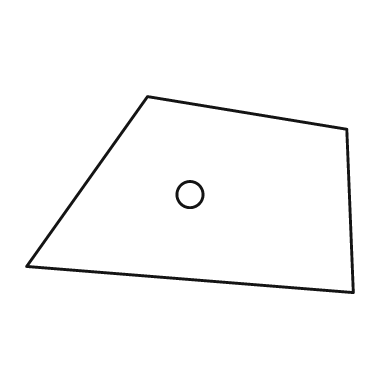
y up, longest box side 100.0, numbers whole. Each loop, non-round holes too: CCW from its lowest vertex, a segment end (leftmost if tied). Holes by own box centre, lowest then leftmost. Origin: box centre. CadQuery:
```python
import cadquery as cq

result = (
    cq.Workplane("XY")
    .moveTo(50.0, -30.0)
    .lineTo(48.0, 20.0)
    .lineTo(-13.0, 30.0)
    .lineTo(-50.0, -22.0)
    .close()
    .moveTo(0.0, 0.0)
    .circle(4.0)
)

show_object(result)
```